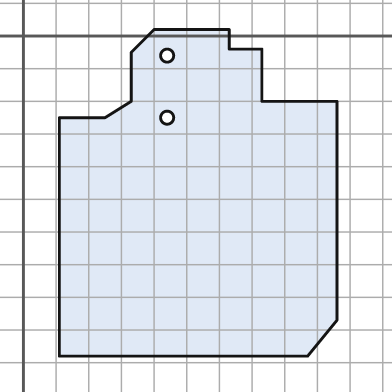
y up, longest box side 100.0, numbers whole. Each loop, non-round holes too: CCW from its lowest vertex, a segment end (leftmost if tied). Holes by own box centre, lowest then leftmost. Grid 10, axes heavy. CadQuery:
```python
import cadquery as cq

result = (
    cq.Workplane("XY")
    .moveTo(11.0, -98.0)
    .lineTo(87.0, -98.0)
    .lineTo(96.0, -87.0)
    .lineTo(96.0, -20.0)
    .lineTo(73.0, -20.0)
    .lineTo(73.0, -4.0)
    .lineTo(63.0, -4.0)
    .lineTo(63.0, 2.0)
    .lineTo(40.0, 2.0)
    .lineTo(33.0, -5.0)
    .lineTo(33.0, -20.0)
    .lineTo(25.0, -25.0)
    .lineTo(11.0, -25.0)
    .close()
    .moveTo(44.0, -25.0)
    .circle(2.0)
    .moveTo(44.0, -6.0)
    .circle(2.0)
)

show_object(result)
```